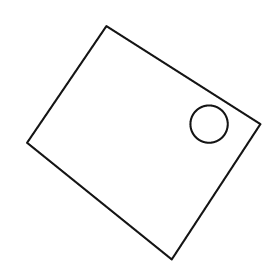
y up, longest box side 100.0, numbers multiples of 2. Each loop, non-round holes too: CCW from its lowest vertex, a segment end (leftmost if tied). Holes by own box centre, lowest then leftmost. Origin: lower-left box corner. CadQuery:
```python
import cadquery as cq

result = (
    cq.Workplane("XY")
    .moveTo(62.0, 0.0)
    .lineTo(100.0, 58.0)
    .lineTo(34.0, 100.0)
    .lineTo(0.0, 50.0)
    .close()
    .moveTo(78.0, 58.0)
    .circle(8.0)
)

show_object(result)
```